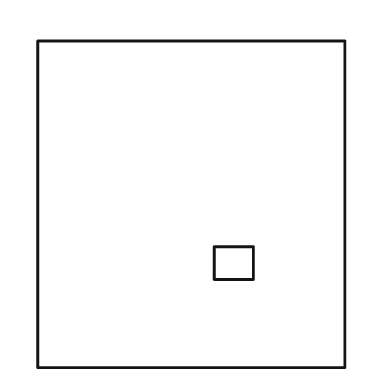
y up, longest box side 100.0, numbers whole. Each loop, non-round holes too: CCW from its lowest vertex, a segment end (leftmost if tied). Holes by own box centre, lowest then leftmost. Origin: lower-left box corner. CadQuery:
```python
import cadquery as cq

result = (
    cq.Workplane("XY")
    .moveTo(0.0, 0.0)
    .lineTo(94.0, 0.0)
    .lineTo(94.0, 100.0)
    .lineTo(0.0, 100.0)
    .close()
    .moveTo(54.0, 27.0)
    .lineTo(66.0, 27.0)
    .lineTo(66.0, 37.0)
    .lineTo(54.0, 37.0)
    .close()
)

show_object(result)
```